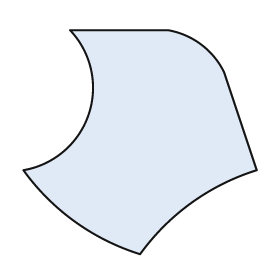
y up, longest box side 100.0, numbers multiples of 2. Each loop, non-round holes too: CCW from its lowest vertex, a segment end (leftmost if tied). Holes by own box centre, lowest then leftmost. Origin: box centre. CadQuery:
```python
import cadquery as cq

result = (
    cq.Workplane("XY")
    .moveTo(0.0, -48.0)
    .threePointArc((22.0, -26.0), (50.0, -12.0))
    .lineTo(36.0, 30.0)
    .threePointArc((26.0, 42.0), (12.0, 48.0))
    .lineTo(-30.0, 48.0)
    .threePointArc((-22.0, 12.0), (-50.0, -12.0))
    .threePointArc((-28.0, -34.0), (0.0, -48.0))
    .close()
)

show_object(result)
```